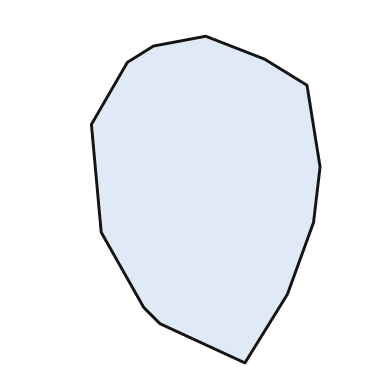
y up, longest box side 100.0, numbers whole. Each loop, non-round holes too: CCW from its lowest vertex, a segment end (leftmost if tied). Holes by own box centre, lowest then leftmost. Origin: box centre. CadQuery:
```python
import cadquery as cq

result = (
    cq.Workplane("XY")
    .moveTo(12.0, -50.0)
    .lineTo(25.0, -29.0)
    .lineTo(33.0, -7.0)
    .lineTo(35.0, 10.0)
    .lineTo(31.0, 35.0)
    .lineTo(18.0, 43.0)
    .lineTo(0.0, 50.0)
    .lineTo(-16.0, 47.0)
    .lineTo(-24.0, 42.0)
    .lineTo(-35.0, 23.0)
    .lineTo(-32.0, -10.0)
    .lineTo(-19.0, -33.0)
    .lineTo(-14.0, -38.0)
    .close()
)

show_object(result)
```